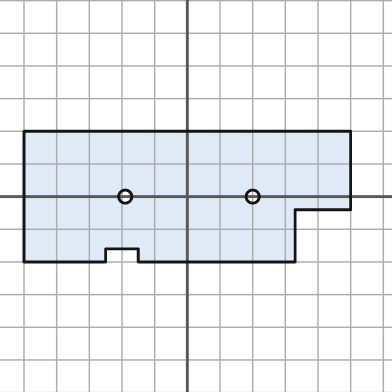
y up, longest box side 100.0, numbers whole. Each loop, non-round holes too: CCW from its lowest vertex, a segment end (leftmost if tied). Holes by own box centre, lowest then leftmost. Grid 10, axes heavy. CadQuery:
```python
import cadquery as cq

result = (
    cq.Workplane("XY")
    .moveTo(-50.0, -20.0)
    .lineTo(-25.0, -20.0)
    .lineTo(-25.0, -16.0)
    .lineTo(-15.0, -16.0)
    .lineTo(-15.0, -20.0)
    .lineTo(33.0, -20.0)
    .lineTo(33.0, -4.0)
    .lineTo(50.0, -4.0)
    .lineTo(50.0, 20.0)
    .lineTo(-50.0, 20.0)
    .close()
    .moveTo(-19.0, 0.0)
    .circle(2.0)
    .moveTo(20.0, 0.0)
    .circle(2.0)
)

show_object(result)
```